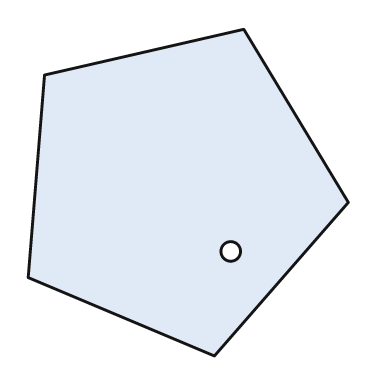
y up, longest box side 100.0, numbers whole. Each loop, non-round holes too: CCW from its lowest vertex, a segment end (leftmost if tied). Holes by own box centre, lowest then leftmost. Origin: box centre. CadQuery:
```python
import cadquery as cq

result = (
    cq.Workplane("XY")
    .moveTo(8.0, -50.0)
    .lineTo(49.0, -3.0)
    .lineTo(17.0, 50.0)
    .lineTo(-44.0, 36.0)
    .lineTo(-49.0, -26.0)
    .close()
    .moveTo(13.0, -18.0)
    .circle(3.0)
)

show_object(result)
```